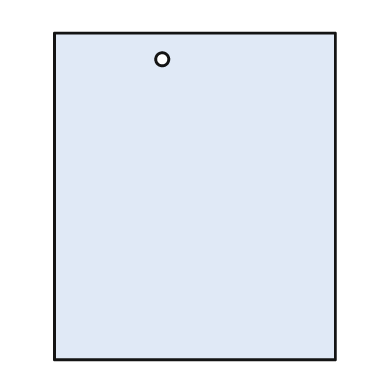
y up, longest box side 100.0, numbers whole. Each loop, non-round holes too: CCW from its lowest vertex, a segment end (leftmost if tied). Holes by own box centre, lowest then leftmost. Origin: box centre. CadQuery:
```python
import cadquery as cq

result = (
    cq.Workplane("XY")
    .moveTo(-43.0, -50.0)
    .lineTo(43.0, -50.0)
    .lineTo(43.0, 50.0)
    .lineTo(-43.0, 50.0)
    .close()
    .moveTo(-10.0, 42.0)
    .circle(2.0)
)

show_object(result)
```